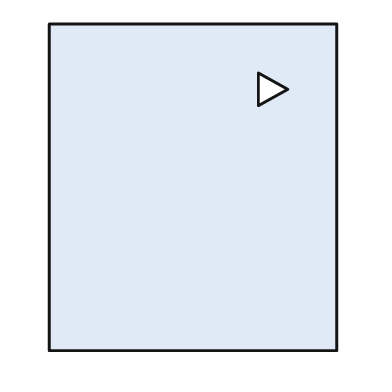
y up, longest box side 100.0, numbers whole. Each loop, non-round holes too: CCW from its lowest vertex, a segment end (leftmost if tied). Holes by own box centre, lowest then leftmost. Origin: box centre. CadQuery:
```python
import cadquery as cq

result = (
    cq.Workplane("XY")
    .moveTo(-44.0, -50.0)
    .lineTo(44.0, -50.0)
    .lineTo(44.0, 50.0)
    .lineTo(-44.0, 50.0)
    .close()
    .moveTo(20.0, 25.0)
    .lineTo(29.0, 30.0)
    .lineTo(20.0, 35.0)
    .close()
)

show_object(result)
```